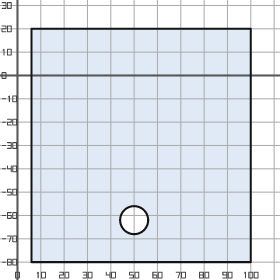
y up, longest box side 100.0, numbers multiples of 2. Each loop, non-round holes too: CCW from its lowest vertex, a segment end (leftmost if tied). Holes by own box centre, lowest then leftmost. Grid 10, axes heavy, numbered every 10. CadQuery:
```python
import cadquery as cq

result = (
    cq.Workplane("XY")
    .moveTo(6.0, -80.0)
    .lineTo(100.0, -80.0)
    .lineTo(100.0, 20.0)
    .lineTo(6.0, 20.0)
    .close()
    .moveTo(50.0, -62.0)
    .circle(6.0)
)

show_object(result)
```